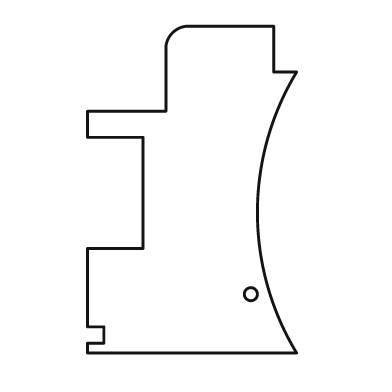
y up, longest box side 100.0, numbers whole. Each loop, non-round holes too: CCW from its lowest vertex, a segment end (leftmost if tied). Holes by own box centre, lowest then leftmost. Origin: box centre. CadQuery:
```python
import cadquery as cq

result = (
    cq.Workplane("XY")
    .moveTo(-32.0, -50.0)
    .lineTo(32.0, -50.0)
    .threePointArc((20.0, -7.0), (32.0, 36.0))
    .lineTo(25.0, 36.0)
    .lineTo(25.0, 50.0)
    .lineTo(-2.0, 50.0)
    .threePointArc((-6.0, 48.0), (-8.0, 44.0))
    .lineTo(-8.0, 24.0)
    .lineTo(-32.0, 24.0)
    .lineTo(-32.0, 16.0)
    .lineTo(-15.0, 16.0)
    .lineTo(-15.0, -18.0)
    .lineTo(-32.0, -18.0)
    .lineTo(-32.0, -42.0)
    .lineTo(-27.0, -42.0)
    .lineTo(-27.0, -47.0)
    .lineTo(-32.0, -47.0)
    .close()
    .moveTo(18.0, -32.0)
    .circle(2.0)
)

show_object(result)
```